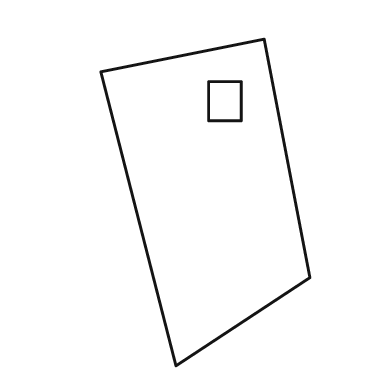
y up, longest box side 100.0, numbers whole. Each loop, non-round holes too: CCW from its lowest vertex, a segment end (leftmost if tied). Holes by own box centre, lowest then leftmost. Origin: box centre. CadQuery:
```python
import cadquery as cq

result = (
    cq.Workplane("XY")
    .moveTo(-9.0, -50.0)
    .lineTo(32.0, -23.0)
    .lineTo(18.0, 50.0)
    .lineTo(-32.0, 40.0)
    .close()
    .moveTo(1.0, 25.0)
    .lineTo(11.0, 25.0)
    .lineTo(11.0, 37.0)
    .lineTo(1.0, 37.0)
    .close()
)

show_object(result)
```